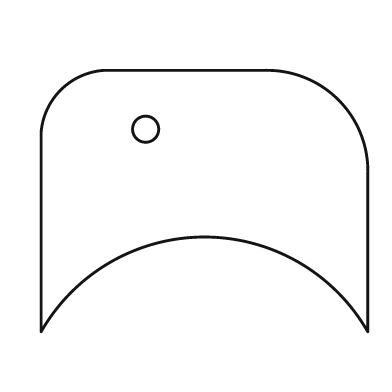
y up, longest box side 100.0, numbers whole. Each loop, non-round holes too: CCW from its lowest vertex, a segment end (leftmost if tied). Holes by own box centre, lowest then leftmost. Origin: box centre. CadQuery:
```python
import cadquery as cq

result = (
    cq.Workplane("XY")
    .moveTo(-50.0, -40.0)
    .threePointArc((0.0, -11.0), (50.0, -40.0))
    .lineTo(50.0, 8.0)
    .threePointArc((41.0, 31.0), (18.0, 40.0))
    .lineTo(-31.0, 40.0)
    .threePointArc((-44.0, 34.0), (-50.0, 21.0))
    .close()
    .moveTo(-18.0, 22.0)
    .circle(4.0)
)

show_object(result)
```